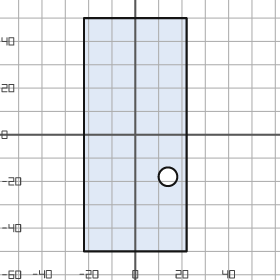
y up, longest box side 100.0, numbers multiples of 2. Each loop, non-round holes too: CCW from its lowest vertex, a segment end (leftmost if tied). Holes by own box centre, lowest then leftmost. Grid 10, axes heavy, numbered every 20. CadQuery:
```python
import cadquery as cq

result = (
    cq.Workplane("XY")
    .moveTo(-22.0, -50.0)
    .lineTo(22.0, -50.0)
    .lineTo(22.0, 50.0)
    .lineTo(-22.0, 50.0)
    .close()
    .moveTo(14.0, -18.0)
    .circle(4.0)
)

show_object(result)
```